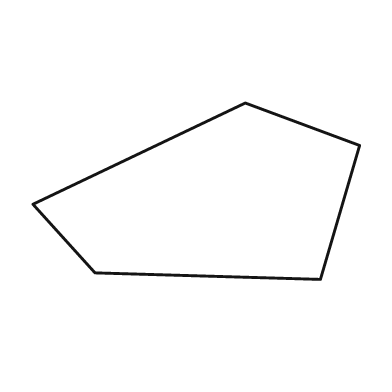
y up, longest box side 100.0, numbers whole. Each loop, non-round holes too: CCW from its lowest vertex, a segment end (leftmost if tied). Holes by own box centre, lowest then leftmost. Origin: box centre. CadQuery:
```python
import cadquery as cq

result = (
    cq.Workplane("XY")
    .moveTo(38.0, -27.0)
    .lineTo(50.0, 14.0)
    .lineTo(15.0, 27.0)
    .lineTo(-50.0, -4.0)
    .lineTo(-31.0, -25.0)
    .close()
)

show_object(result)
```